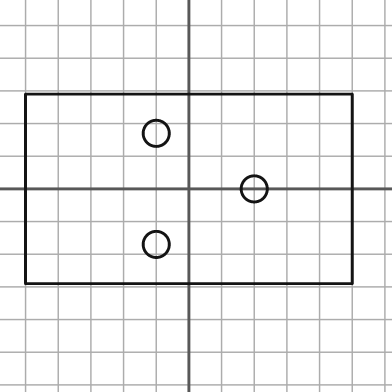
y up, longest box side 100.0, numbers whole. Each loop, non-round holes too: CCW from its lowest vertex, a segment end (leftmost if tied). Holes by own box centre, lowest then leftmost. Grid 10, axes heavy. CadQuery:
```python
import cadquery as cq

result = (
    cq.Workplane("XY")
    .moveTo(-50.0, -29.0)
    .lineTo(50.0, -29.0)
    .lineTo(50.0, 29.0)
    .lineTo(-50.0, 29.0)
    .close()
    .moveTo(-10.0, -17.0)
    .circle(4.0)
    .moveTo(20.0, 0.0)
    .circle(4.0)
    .moveTo(-10.0, 17.0)
    .circle(4.0)
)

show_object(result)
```